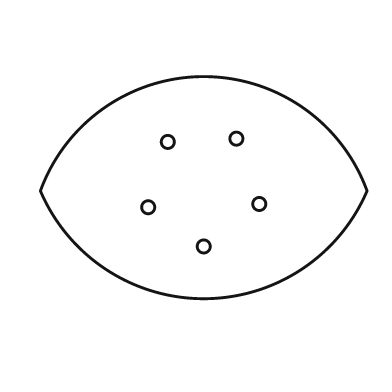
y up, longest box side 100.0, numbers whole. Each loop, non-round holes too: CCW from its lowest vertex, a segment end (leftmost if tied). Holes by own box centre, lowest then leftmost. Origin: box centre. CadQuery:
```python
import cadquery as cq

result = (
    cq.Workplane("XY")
    .moveTo(-50.0, -1.0)
    .threePointArc((0.0, -34.0), (50.0, -1.0))
    .threePointArc((0.0, 34.0), (-50.0, -1.0))
    .close()
    .moveTo(0.0, -18.0)
    .circle(2.0)
    .moveTo(-17.0, -6.0)
    .circle(2.0)
    .moveTo(17.0, -5.0)
    .circle(2.0)
    .moveTo(-11.0, 14.0)
    .circle(2.0)
    .moveTo(10.0, 15.0)
    .circle(2.0)
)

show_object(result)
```